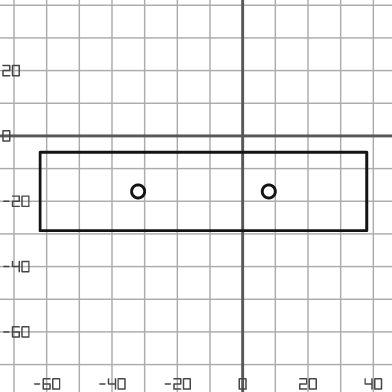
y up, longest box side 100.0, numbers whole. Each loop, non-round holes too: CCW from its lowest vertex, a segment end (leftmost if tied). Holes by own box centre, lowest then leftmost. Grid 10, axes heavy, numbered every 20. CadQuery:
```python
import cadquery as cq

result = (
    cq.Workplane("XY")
    .moveTo(-62.0, -29.0)
    .lineTo(38.0, -29.0)
    .lineTo(38.0, -5.0)
    .lineTo(-62.0, -5.0)
    .close()
    .moveTo(-32.0, -17.0)
    .circle(2.0)
    .moveTo(8.0, -17.0)
    .circle(2.0)
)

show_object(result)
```